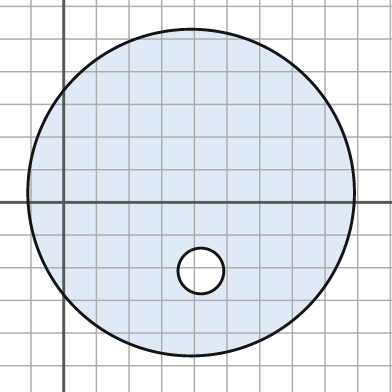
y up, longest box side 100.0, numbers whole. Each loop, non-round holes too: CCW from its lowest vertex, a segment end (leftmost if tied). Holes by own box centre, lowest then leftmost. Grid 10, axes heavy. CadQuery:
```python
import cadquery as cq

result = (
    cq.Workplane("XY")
    .moveTo(39.0, 3.0)
    .circle(50.0)
    .moveTo(42.0, -21.0)
    .circle(7.0)
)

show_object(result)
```